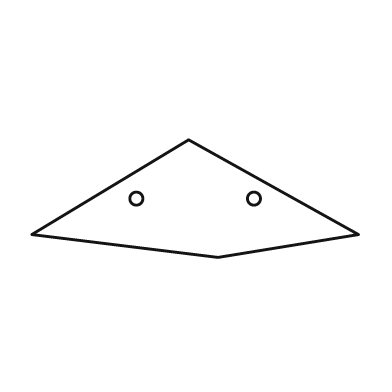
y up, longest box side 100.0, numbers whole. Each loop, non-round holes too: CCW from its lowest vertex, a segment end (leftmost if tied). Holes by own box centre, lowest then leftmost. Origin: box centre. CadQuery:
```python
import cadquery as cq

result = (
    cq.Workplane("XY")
    .moveTo(7.0, -18.0)
    .lineTo(50.0, -11.0)
    .lineTo(-2.0, 18.0)
    .lineTo(-50.0, -11.0)
    .close()
    .moveTo(-18.0, 0.0)
    .circle(2.0)
    .moveTo(18.0, 0.0)
    .circle(2.0)
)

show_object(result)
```